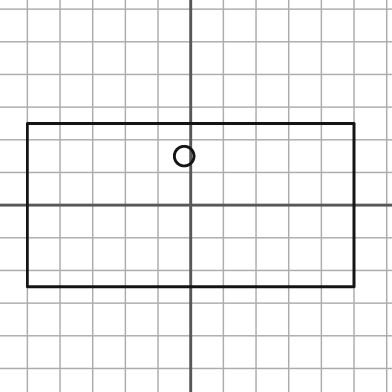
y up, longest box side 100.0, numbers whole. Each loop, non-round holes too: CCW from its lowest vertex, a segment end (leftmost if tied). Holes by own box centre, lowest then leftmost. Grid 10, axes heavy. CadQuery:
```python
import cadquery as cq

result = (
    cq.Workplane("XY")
    .moveTo(-50.0, -25.0)
    .lineTo(50.0, -25.0)
    .lineTo(50.0, 25.0)
    .lineTo(-50.0, 25.0)
    .close()
    .moveTo(-2.0, 15.0)
    .circle(3.0)
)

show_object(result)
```